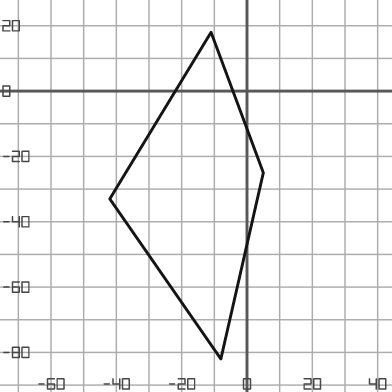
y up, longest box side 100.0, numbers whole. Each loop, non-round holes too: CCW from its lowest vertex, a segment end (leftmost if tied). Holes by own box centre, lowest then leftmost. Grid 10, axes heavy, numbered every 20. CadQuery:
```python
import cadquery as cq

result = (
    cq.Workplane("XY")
    .moveTo(-8.0, -82.0)
    .lineTo(5.0, -25.0)
    .lineTo(-11.0, 18.0)
    .lineTo(-42.0, -33.0)
    .close()
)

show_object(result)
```